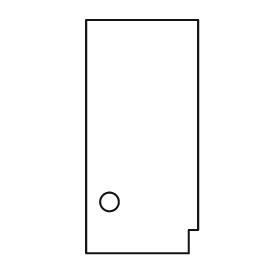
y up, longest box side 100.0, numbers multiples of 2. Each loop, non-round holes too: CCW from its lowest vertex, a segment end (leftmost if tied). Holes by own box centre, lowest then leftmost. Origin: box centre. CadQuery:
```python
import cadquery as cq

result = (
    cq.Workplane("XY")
    .moveTo(-24.0, -50.0)
    .lineTo(20.0, -50.0)
    .lineTo(20.0, -40.0)
    .lineTo(24.0, -40.0)
    .lineTo(24.0, 50.0)
    .lineTo(-24.0, 50.0)
    .close()
    .moveTo(-14.0, -28.0)
    .circle(4.0)
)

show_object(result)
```